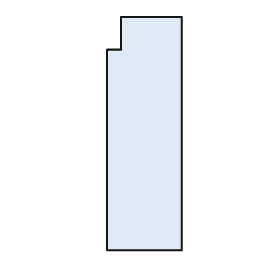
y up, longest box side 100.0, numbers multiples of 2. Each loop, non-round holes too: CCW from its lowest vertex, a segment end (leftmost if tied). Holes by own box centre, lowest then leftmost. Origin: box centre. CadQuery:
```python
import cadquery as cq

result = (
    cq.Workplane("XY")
    .moveTo(-16.0, -50.0)
    .lineTo(16.0, -50.0)
    .lineTo(16.0, 50.0)
    .lineTo(-10.0, 50.0)
    .lineTo(-10.0, 36.0)
    .lineTo(-16.0, 36.0)
    .close()
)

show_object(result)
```